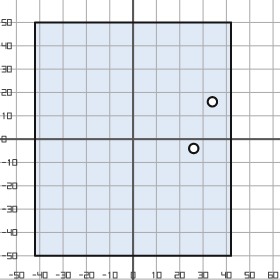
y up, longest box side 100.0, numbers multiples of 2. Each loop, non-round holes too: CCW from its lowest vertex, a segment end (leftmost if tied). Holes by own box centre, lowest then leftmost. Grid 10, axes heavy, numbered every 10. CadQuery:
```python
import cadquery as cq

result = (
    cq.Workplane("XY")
    .moveTo(-42.0, -50.0)
    .lineTo(42.0, -50.0)
    .lineTo(42.0, 50.0)
    .lineTo(-42.0, 50.0)
    .close()
    .moveTo(26.0, -4.0)
    .circle(2.0)
    .moveTo(34.0, 16.0)
    .circle(2.0)
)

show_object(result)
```